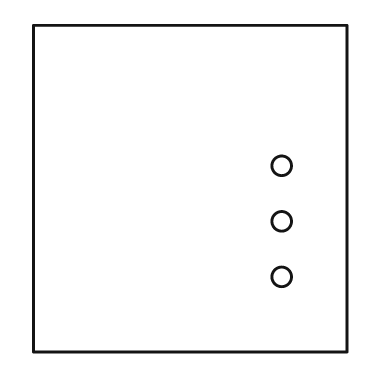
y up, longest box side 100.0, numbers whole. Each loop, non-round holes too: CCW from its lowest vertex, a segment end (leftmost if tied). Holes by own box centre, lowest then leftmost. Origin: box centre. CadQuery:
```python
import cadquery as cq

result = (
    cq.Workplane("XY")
    .moveTo(-48.0, -50.0)
    .lineTo(48.0, -50.0)
    .lineTo(48.0, 50.0)
    .lineTo(-48.0, 50.0)
    .close()
    .moveTo(28.0, -27.0)
    .circle(3.0)
    .moveTo(28.0, -10.0)
    .circle(3.0)
    .moveTo(28.0, 7.0)
    .circle(3.0)
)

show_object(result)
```